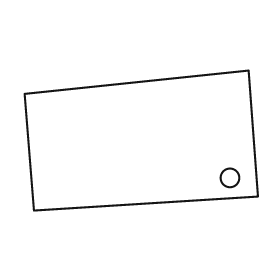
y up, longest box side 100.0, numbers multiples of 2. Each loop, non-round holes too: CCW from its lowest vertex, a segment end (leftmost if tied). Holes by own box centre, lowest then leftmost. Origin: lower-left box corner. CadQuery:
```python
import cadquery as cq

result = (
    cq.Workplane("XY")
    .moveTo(4.0, 0.0)
    .lineTo(100.0, 6.0)
    .lineTo(96.0, 60.0)
    .lineTo(0.0, 50.0)
    .close()
    .moveTo(88.0, 14.0)
    .circle(4.0)
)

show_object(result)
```